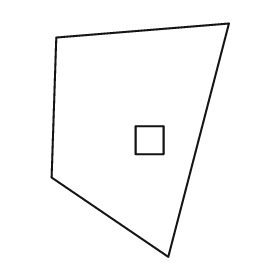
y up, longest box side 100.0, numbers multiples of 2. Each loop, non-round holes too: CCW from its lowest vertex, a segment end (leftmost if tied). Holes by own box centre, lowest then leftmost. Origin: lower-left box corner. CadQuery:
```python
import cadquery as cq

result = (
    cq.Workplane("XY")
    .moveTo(50.0, 0.0)
    .lineTo(76.0, 100.0)
    .lineTo(2.0, 94.0)
    .lineTo(0.0, 34.0)
    .close()
    .moveTo(36.0, 44.0)
    .lineTo(48.0, 44.0)
    .lineTo(48.0, 56.0)
    .lineTo(36.0, 56.0)
    .close()
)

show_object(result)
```